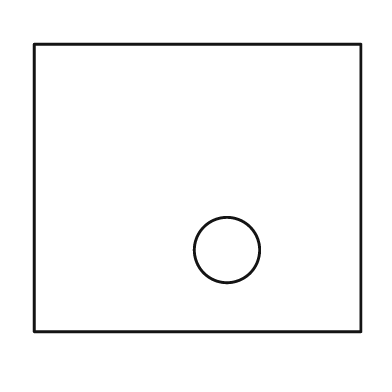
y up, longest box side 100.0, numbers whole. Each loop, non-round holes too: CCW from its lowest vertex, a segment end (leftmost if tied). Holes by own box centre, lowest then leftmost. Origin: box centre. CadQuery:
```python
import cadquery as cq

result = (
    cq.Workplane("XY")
    .moveTo(-50.0, -44.0)
    .lineTo(50.0, -44.0)
    .lineTo(50.0, 44.0)
    .lineTo(-50.0, 44.0)
    .close()
    .moveTo(9.0, -19.0)
    .circle(10.0)
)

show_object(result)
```